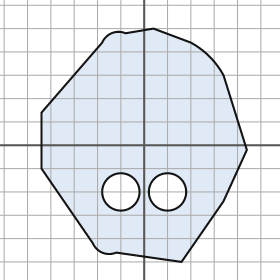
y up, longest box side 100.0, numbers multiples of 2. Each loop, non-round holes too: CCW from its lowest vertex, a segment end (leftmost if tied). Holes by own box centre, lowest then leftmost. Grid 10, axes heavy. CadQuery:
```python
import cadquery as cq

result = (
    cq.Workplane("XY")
    .moveTo(16.0, -50.0)
    .lineTo(34.0, -24.0)
    .lineTo(44.0, -2.0)
    .lineTo(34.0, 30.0)
    .threePointArc((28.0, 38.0), (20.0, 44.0))
    .lineTo(4.0, 50.0)
    .lineTo(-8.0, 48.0)
    .threePointArc((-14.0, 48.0), (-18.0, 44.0))
    .lineTo(-44.0, 14.0)
    .lineTo(-44.0, -10.0)
    .lineTo(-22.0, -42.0)
    .threePointArc((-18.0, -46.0), (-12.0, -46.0))
    .close()
    .moveTo(-10.0, -20.0)
    .circle(8.0)
    .moveTo(10.0, -20.0)
    .circle(8.0)
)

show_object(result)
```